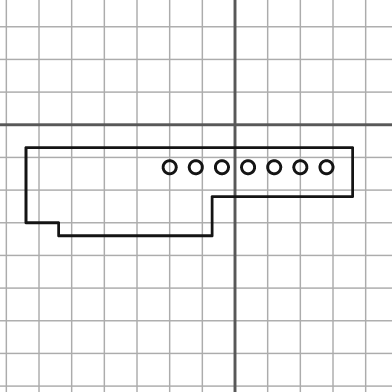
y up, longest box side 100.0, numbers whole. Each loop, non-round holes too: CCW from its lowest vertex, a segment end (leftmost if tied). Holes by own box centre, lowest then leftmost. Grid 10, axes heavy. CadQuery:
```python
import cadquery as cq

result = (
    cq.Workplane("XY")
    .moveTo(-54.0, -34.0)
    .lineTo(-7.0, -34.0)
    .lineTo(-7.0, -22.0)
    .lineTo(36.0, -22.0)
    .lineTo(36.0, -7.0)
    .lineTo(-64.0, -7.0)
    .lineTo(-64.0, -30.0)
    .lineTo(-54.0, -30.0)
    .close()
    .moveTo(-20.0, -13.0)
    .circle(2.0)
    .moveTo(-12.0, -13.0)
    .circle(2.0)
    .moveTo(-4.0, -13.0)
    .circle(2.0)
    .moveTo(4.0, -13.0)
    .circle(2.0)
    .moveTo(12.0, -13.0)
    .circle(2.0)
    .moveTo(20.0, -13.0)
    .circle(2.0)
    .moveTo(28.0, -13.0)
    .circle(2.0)
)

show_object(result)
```